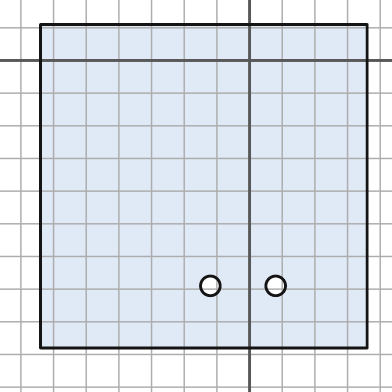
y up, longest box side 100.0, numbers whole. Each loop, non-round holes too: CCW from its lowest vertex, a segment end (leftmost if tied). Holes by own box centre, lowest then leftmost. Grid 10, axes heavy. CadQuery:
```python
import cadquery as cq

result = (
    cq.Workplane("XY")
    .moveTo(-64.0, -88.0)
    .lineTo(36.0, -88.0)
    .lineTo(36.0, 11.0)
    .lineTo(-64.0, 11.0)
    .close()
    .moveTo(-12.0, -69.0)
    .circle(3.0)
    .moveTo(8.0, -69.0)
    .circle(3.0)
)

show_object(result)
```